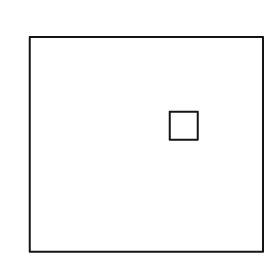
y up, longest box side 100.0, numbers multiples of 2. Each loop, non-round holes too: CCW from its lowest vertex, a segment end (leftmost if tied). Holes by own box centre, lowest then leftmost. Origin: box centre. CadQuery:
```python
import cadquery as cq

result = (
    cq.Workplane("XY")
    .moveTo(-50.0, -46.0)
    .lineTo(50.0, -46.0)
    .lineTo(50.0, 46.0)
    .lineTo(-50.0, 46.0)
    .close()
    .moveTo(10.0, 2.0)
    .lineTo(22.0, 2.0)
    .lineTo(22.0, 14.0)
    .lineTo(10.0, 14.0)
    .close()
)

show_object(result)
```